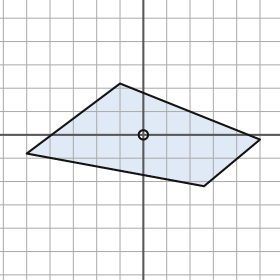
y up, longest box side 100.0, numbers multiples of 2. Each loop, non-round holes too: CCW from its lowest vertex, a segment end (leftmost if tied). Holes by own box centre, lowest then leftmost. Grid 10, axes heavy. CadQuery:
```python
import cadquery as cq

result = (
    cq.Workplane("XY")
    .moveTo(26.0, -22.0)
    .lineTo(50.0, -2.0)
    .lineTo(-10.0, 22.0)
    .lineTo(-50.0, -8.0)
    .close()
    .moveTo(0.0, 0.0)
    .circle(2.0)
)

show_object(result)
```